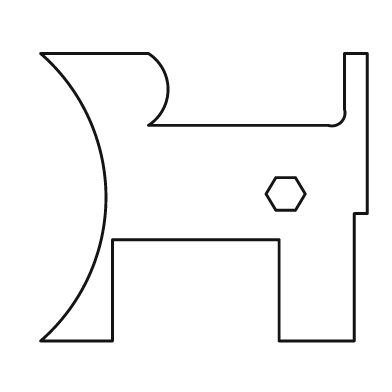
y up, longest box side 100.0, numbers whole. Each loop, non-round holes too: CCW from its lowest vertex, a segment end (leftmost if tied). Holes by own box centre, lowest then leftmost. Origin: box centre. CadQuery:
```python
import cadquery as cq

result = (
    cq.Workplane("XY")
    .moveTo(-50.0, -44.0)
    .lineTo(-28.0, -44.0)
    .lineTo(-28.0, -13.0)
    .lineTo(23.0, -13.0)
    .lineTo(23.0, -44.0)
    .lineTo(46.0, -44.0)
    .lineTo(46.0, -5.0)
    .lineTo(50.0, -5.0)
    .lineTo(50.0, 44.0)
    .lineTo(43.0, 44.0)
    .lineTo(43.0, 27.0)
    .threePointArc((42.0, 23.0), (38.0, 22.0))
    .lineTo(-17.0, 22.0)
    .threePointArc((-11.0, 33.0), (-17.0, 44.0))
    .lineTo(-50.0, 44.0)
    .threePointArc((-30.0, 0.0), (-50.0, -44.0))
    .close()
    .moveTo(22.0, -4.0)
    .lineTo(28.0, -4.0)
    .lineTo(31.0, 1.0)
    .lineTo(28.0, 6.0)
    .lineTo(22.0, 6.0)
    .lineTo(19.0, 1.0)
    .close()
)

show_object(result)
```